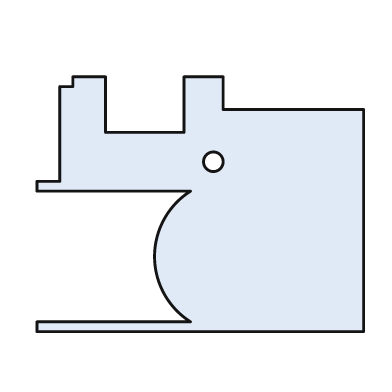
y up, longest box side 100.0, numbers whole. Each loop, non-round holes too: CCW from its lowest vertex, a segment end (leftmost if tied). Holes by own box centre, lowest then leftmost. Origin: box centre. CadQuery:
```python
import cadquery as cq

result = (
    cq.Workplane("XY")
    .moveTo(-50.0, -39.0)
    .lineTo(50.0, -39.0)
    .lineTo(50.0, 29.0)
    .lineTo(7.0, 29.0)
    .lineTo(7.0, 39.0)
    .lineTo(-5.0, 39.0)
    .lineTo(-5.0, 22.0)
    .lineTo(-29.0, 22.0)
    .lineTo(-29.0, 39.0)
    .lineTo(-39.0, 39.0)
    .lineTo(-39.0, 36.0)
    .lineTo(-43.0, 36.0)
    .lineTo(-43.0, 7.0)
    .lineTo(-50.0, 7.0)
    .lineTo(-50.0, 4.0)
    .lineTo(-3.0, 4.0)
    .threePointArc((-14.0, -16.0), (-3.0, -36.0))
    .lineTo(-50.0, -36.0)
    .close()
    .moveTo(4.0, 13.0)
    .circle(3.0)
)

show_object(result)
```